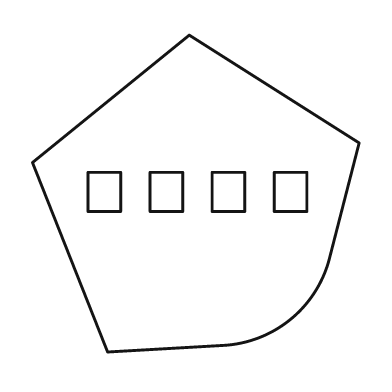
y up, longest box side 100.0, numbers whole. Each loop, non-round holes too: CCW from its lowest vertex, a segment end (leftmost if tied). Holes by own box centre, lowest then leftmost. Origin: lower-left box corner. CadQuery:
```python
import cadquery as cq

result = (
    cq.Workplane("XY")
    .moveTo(23.0, 0.0)
    .lineTo(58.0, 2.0)
    .threePointArc((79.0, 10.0), (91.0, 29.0))
    .lineTo(100.0, 64.0)
    .lineTo(48.0, 97.0)
    .lineTo(0.0, 58.0)
    .close()
    .moveTo(17.0, 43.0)
    .lineTo(27.0, 43.0)
    .lineTo(27.0, 55.0)
    .lineTo(17.0, 55.0)
    .close()
    .moveTo(36.0, 43.0)
    .lineTo(46.0, 43.0)
    .lineTo(46.0, 55.0)
    .lineTo(36.0, 55.0)
    .close()
    .moveTo(55.0, 43.0)
    .lineTo(65.0, 43.0)
    .lineTo(65.0, 55.0)
    .lineTo(55.0, 55.0)
    .close()
    .moveTo(74.0, 43.0)
    .lineTo(84.0, 43.0)
    .lineTo(84.0, 55.0)
    .lineTo(74.0, 55.0)
    .close()
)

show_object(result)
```